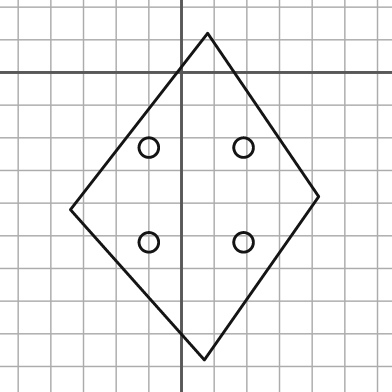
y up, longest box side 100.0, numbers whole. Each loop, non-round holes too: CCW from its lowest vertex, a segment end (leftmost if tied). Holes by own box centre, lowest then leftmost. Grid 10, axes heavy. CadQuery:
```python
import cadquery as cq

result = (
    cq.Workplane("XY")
    .moveTo(7.0, -88.0)
    .lineTo(42.0, -38.0)
    .lineTo(8.0, 12.0)
    .lineTo(-34.0, -42.0)
    .close()
    .moveTo(-10.0, -52.0)
    .circle(3.0)
    .moveTo(19.0, -52.0)
    .circle(3.0)
    .moveTo(-10.0, -23.0)
    .circle(3.0)
    .moveTo(19.0, -23.0)
    .circle(3.0)
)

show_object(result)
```